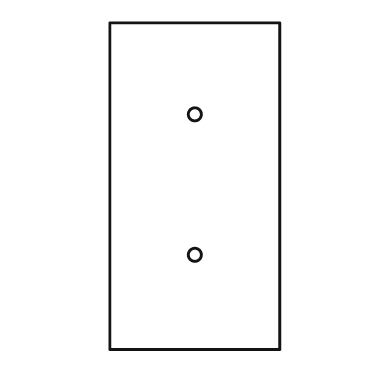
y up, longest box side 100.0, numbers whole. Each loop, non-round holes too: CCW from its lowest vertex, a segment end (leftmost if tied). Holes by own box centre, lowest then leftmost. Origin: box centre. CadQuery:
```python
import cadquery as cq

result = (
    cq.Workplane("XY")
    .moveTo(-26.0, -50.0)
    .lineTo(26.0, -50.0)
    .lineTo(26.0, 50.0)
    .lineTo(-26.0, 50.0)
    .close()
    .moveTo(0.0, -21.0)
    .circle(2.0)
    .moveTo(0.0, 22.0)
    .circle(2.0)
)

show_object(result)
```